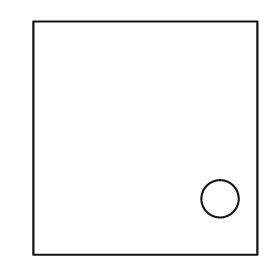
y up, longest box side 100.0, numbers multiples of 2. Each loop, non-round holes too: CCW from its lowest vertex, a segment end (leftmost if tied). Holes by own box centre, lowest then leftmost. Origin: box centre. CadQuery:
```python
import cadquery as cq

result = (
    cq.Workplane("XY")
    .moveTo(-48.0, -50.0)
    .lineTo(48.0, -50.0)
    .lineTo(48.0, 50.0)
    .lineTo(-48.0, 50.0)
    .close()
    .moveTo(32.0, -26.0)
    .circle(8.0)
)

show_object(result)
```